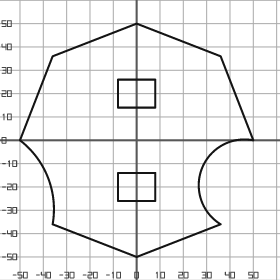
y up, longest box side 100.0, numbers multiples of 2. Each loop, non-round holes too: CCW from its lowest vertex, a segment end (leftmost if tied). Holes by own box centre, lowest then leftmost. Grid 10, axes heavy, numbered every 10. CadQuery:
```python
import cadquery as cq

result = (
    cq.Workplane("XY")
    .moveTo(0.0, -50.0)
    .lineTo(36.0, -36.0)
    .threePointArc((28.0, -12.0), (50.0, 0.0))
    .lineTo(36.0, 36.0)
    .lineTo(0.0, 50.0)
    .lineTo(-36.0, 36.0)
    .lineTo(-50.0, 0.0)
    .threePointArc((-38.0, -16.0), (-36.0, -36.0))
    .close()
    .moveTo(-8.0, -26.0)
    .lineTo(8.0, -26.0)
    .lineTo(8.0, -14.0)
    .lineTo(-8.0, -14.0)
    .close()
    .moveTo(-8.0, 14.0)
    .lineTo(8.0, 14.0)
    .lineTo(8.0, 26.0)
    .lineTo(-8.0, 26.0)
    .close()
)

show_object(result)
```